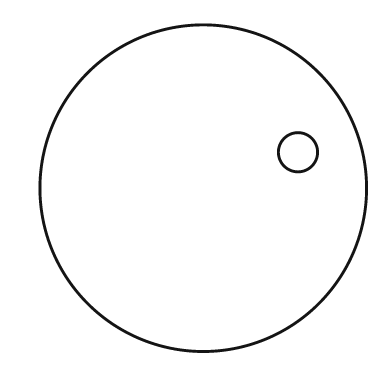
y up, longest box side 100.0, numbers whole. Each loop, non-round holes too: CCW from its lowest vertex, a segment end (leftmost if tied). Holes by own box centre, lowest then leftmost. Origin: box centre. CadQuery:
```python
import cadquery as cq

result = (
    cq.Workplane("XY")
    .moveTo(0.0, 0.0)
    .circle(50.0)
    .moveTo(29.0, 11.0)
    .circle(6.0)
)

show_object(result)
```